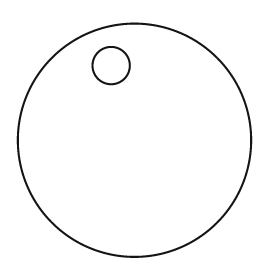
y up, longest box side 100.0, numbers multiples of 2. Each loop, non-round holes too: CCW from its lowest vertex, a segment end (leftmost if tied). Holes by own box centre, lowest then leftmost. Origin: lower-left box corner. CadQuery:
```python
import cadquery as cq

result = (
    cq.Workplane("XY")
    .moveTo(50.0, 50.0)
    .circle(50.0)
    .moveTo(40.0, 82.0)
    .circle(8.0)
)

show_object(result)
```